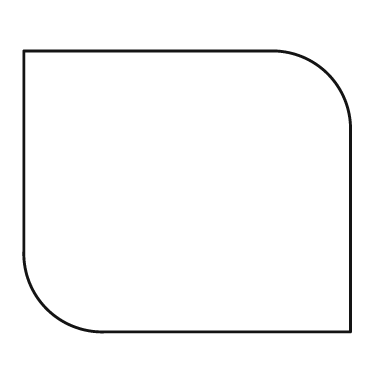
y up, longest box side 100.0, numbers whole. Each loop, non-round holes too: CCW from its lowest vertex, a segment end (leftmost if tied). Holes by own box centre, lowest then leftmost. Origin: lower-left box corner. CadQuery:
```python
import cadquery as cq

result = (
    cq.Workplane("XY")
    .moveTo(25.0, 0.0)
    .lineTo(100.0, 0.0)
    .lineTo(100.0, 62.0)
    .threePointArc((93.0, 79.0), (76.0, 86.0))
    .lineTo(0.0, 86.0)
    .lineTo(0.0, 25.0)
    .threePointArc((7.0, 7.0), (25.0, 0.0))
    .close()
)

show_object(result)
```